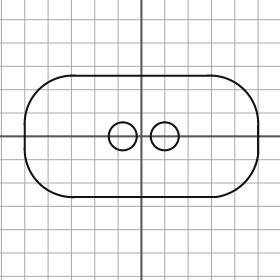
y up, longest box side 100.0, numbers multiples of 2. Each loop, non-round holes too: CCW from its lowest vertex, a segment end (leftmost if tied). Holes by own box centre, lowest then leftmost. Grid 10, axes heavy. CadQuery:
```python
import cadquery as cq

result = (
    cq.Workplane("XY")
    .moveTo(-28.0, -26.0)
    .lineTo(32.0, -26.0)
    .threePointArc((44.0, -20.0), (50.0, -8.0))
    .lineTo(50.0, 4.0)
    .threePointArc((44.0, 20.0), (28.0, 26.0))
    .lineTo(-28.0, 26.0)
    .threePointArc((-44.0, 20.0), (-50.0, 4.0))
    .lineTo(-50.0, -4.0)
    .threePointArc((-44.0, -20.0), (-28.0, -26.0))
    .close()
    .moveTo(-8.0, 0.0)
    .circle(6.0)
    .moveTo(10.0, 0.0)
    .circle(6.0)
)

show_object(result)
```